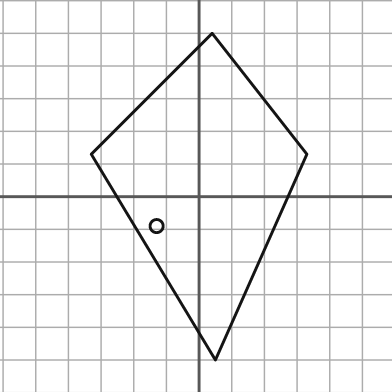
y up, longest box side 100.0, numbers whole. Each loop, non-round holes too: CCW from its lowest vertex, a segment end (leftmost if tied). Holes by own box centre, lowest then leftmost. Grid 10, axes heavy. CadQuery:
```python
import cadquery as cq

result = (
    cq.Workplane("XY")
    .moveTo(5.0, -50.0)
    .lineTo(33.0, 13.0)
    .lineTo(4.0, 50.0)
    .lineTo(-33.0, 13.0)
    .close()
    .moveTo(-13.0, -9.0)
    .circle(2.0)
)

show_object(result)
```